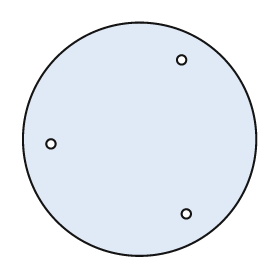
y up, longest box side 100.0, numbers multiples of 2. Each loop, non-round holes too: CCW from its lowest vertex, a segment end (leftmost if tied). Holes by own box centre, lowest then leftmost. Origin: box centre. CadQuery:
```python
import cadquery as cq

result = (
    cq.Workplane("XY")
    .moveTo(0.0, 0.0)
    .circle(50.0)
    .moveTo(20.0, -32.0)
    .circle(2.0)
    .moveTo(-38.0, -2.0)
    .circle(2.0)
    .moveTo(18.0, 34.0)
    .circle(2.0)
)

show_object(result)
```